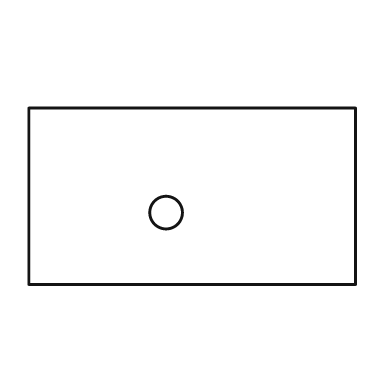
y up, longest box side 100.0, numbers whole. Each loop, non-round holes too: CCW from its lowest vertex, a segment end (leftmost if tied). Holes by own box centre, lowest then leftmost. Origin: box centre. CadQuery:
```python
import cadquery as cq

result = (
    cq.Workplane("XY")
    .moveTo(-50.0, -27.0)
    .lineTo(50.0, -27.0)
    .lineTo(50.0, 27.0)
    .lineTo(-50.0, 27.0)
    .close()
    .moveTo(-8.0, -5.0)
    .circle(5.0)
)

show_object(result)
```